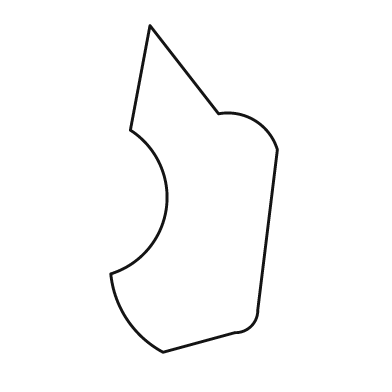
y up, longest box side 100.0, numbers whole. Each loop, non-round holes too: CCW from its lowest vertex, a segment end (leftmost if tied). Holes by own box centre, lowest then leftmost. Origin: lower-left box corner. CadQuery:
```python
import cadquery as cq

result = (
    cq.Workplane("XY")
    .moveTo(16.0, 0.0)
    .lineTo(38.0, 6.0)
    .threePointArc((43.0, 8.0), (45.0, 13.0))
    .lineTo(51.0, 62.0)
    .threePointArc((44.0, 71.0), (33.0, 73.0))
    .lineTo(12.0, 100.0)
    .lineTo(6.0, 68.0)
    .threePointArc((17.0, 44.0), (0.0, 24.0))
    .threePointArc((5.0, 10.0), (16.0, 0.0))
    .close()
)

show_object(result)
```